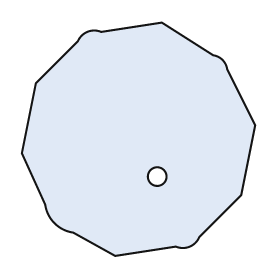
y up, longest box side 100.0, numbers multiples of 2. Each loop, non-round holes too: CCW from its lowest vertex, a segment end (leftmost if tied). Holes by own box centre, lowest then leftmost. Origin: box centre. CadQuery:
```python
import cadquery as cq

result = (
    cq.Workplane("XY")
    .moveTo(-10.0, -50.0)
    .lineTo(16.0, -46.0)
    .threePointArc((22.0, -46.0), (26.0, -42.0))
    .lineTo(44.0, -24.0)
    .lineTo(50.0, 6.0)
    .lineTo(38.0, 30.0)
    .threePointArc((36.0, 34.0), (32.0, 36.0))
    .lineTo(10.0, 50.0)
    .lineTo(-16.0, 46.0)
    .threePointArc((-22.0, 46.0), (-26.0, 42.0))
    .lineTo(-44.0, 24.0)
    .lineTo(-50.0, -6.0)
    .lineTo(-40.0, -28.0)
    .threePointArc((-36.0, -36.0), (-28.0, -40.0))
    .close()
    .moveTo(8.0, -16.0)
    .circle(4.0)
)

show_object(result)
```